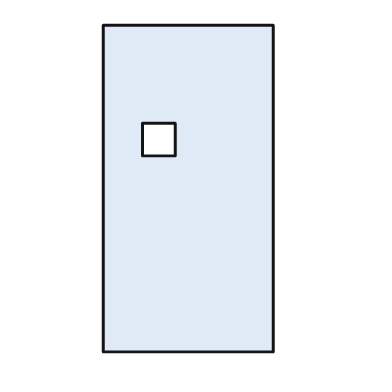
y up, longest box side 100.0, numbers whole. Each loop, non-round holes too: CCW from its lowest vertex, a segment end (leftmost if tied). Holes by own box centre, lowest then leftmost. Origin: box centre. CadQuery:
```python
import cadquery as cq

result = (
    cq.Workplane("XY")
    .moveTo(-26.0, -50.0)
    .lineTo(26.0, -50.0)
    .lineTo(26.0, 50.0)
    .lineTo(-26.0, 50.0)
    .close()
    .moveTo(-14.0, 10.0)
    .lineTo(-4.0, 10.0)
    .lineTo(-4.0, 20.0)
    .lineTo(-14.0, 20.0)
    .close()
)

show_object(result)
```